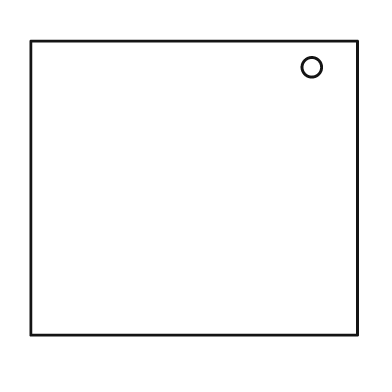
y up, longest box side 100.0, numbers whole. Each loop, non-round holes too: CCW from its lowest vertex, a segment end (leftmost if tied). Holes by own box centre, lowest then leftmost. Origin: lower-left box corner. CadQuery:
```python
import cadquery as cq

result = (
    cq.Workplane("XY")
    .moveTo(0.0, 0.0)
    .lineTo(100.0, 0.0)
    .lineTo(100.0, 90.0)
    .lineTo(0.0, 90.0)
    .close()
    .moveTo(86.0, 82.0)
    .circle(3.0)
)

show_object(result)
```